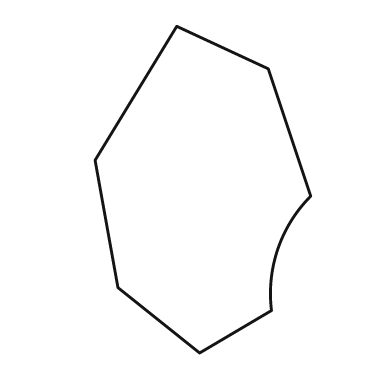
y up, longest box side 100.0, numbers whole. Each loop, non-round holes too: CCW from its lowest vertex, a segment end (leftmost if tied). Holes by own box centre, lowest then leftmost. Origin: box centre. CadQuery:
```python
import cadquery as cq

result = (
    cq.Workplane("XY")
    .moveTo(-1.0, -50.0)
    .lineTo(21.0, -37.0)
    .threePointArc((23.0, -18.0), (33.0, -2.0))
    .lineTo(20.0, 37.0)
    .lineTo(-8.0, 50.0)
    .lineTo(-33.0, 9.0)
    .lineTo(-26.0, -30.0)
    .close()
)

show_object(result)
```